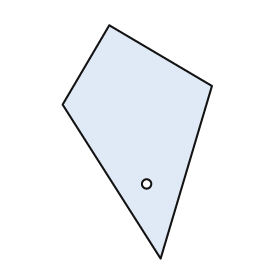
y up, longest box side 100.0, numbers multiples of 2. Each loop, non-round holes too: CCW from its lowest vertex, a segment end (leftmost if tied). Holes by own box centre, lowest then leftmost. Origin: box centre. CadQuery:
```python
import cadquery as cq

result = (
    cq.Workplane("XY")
    .moveTo(10.0, -50.0)
    .lineTo(32.0, 24.0)
    .lineTo(-12.0, 50.0)
    .lineTo(-32.0, 16.0)
    .close()
    .moveTo(4.0, -18.0)
    .circle(2.0)
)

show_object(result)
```